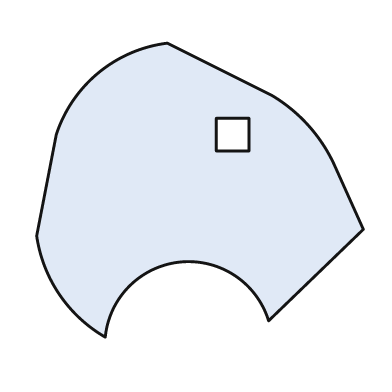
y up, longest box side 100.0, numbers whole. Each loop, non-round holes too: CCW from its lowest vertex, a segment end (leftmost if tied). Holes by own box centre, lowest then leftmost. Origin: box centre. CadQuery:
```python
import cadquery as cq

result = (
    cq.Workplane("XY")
    .moveTo(-29.0, -45.0)
    .threePointArc((-6.0, -22.0), (21.0, -40.0))
    .lineTo(50.0, -12.0)
    .lineTo(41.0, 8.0)
    .threePointArc((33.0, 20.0), (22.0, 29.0))
    .lineTo(-10.0, 45.0)
    .threePointArc((-31.0, 36.0), (-44.0, 17.0))
    .lineTo(-50.0, -14.0)
    .threePointArc((-43.0, -32.0), (-29.0, -45.0))
    .close()
    .moveTo(5.0, 12.0)
    .lineTo(15.0, 12.0)
    .lineTo(15.0, 22.0)
    .lineTo(5.0, 22.0)
    .close()
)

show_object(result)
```